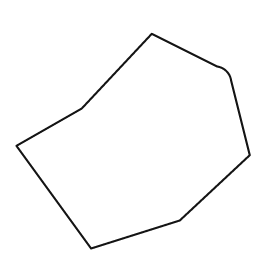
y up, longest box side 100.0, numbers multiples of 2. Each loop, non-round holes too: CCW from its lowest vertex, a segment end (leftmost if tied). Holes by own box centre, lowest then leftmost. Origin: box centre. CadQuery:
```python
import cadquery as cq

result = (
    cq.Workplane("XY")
    .moveTo(-18.0, -46.0)
    .lineTo(20.0, -34.0)
    .lineTo(50.0, -6.0)
    .lineTo(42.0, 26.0)
    .threePointArc((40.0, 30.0), (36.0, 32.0))
    .lineTo(8.0, 46.0)
    .lineTo(-22.0, 14.0)
    .lineTo(-50.0, -2.0)
    .close()
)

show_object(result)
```